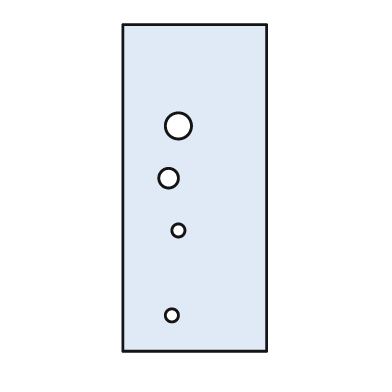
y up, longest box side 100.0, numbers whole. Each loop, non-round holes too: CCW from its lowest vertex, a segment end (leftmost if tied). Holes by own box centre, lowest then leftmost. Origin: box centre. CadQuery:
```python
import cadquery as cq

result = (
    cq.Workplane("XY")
    .moveTo(-22.0, -50.0)
    .lineTo(22.0, -50.0)
    .lineTo(22.0, 50.0)
    .lineTo(-22.0, 50.0)
    .close()
    .moveTo(-7.0, -39.0)
    .circle(2.0)
    .moveTo(-5.0, -13.0)
    .circle(2.0)
    .moveTo(-8.0, 3.0)
    .circle(3.0)
    .moveTo(-5.0, 19.0)
    .circle(4.0)
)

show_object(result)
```